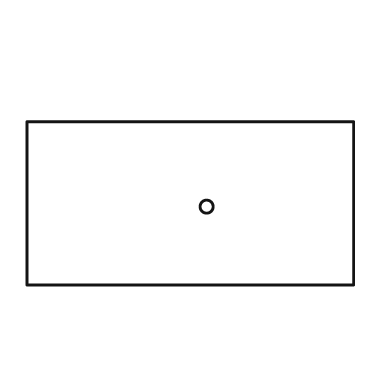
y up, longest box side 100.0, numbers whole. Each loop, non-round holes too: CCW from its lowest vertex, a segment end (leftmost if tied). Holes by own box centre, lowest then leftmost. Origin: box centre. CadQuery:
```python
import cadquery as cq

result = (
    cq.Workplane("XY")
    .moveTo(-50.0, -25.0)
    .lineTo(50.0, -25.0)
    .lineTo(50.0, 25.0)
    .lineTo(-50.0, 25.0)
    .close()
    .moveTo(5.0, -1.0)
    .circle(2.0)
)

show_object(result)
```